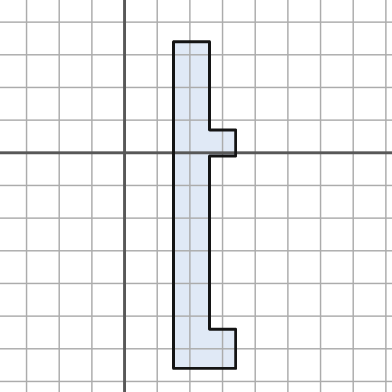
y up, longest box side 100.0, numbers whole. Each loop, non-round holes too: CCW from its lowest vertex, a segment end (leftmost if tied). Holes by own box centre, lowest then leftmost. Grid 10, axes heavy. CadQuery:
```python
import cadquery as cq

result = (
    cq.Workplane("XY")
    .moveTo(15.0, -66.0)
    .lineTo(34.0, -66.0)
    .lineTo(34.0, -54.0)
    .lineTo(26.0, -54.0)
    .lineTo(26.0, -1.0)
    .lineTo(34.0, -1.0)
    .lineTo(34.0, 7.0)
    .lineTo(26.0, 7.0)
    .lineTo(26.0, 34.0)
    .lineTo(15.0, 34.0)
    .close()
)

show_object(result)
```